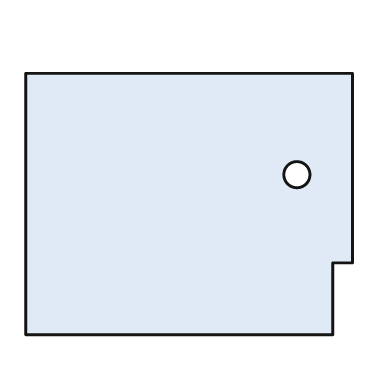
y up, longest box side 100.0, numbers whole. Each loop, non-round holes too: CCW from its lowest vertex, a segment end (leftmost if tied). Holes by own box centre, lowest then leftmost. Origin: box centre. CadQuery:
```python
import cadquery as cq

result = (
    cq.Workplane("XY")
    .moveTo(-50.0, -40.0)
    .lineTo(44.0, -40.0)
    .lineTo(44.0, -18.0)
    .lineTo(50.0, -18.0)
    .lineTo(50.0, 40.0)
    .lineTo(-50.0, 40.0)
    .close()
    .moveTo(33.0, 9.0)
    .circle(4.0)
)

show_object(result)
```